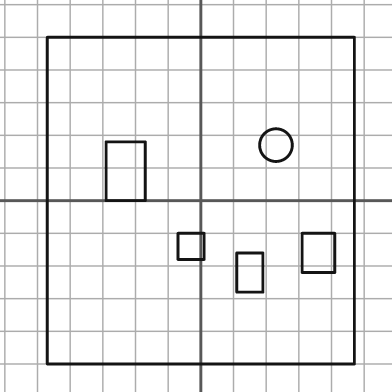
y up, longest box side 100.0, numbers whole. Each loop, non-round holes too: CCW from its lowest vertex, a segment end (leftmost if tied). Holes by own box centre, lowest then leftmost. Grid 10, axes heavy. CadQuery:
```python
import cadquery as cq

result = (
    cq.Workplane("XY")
    .moveTo(-47.0, -50.0)
    .lineTo(47.0, -50.0)
    .lineTo(47.0, 50.0)
    .lineTo(-47.0, 50.0)
    .close()
    .moveTo(11.0, -28.0)
    .lineTo(19.0, -28.0)
    .lineTo(19.0, -16.0)
    .lineTo(11.0, -16.0)
    .close()
    .moveTo(31.0, -22.0)
    .lineTo(41.0, -22.0)
    .lineTo(41.0, -10.0)
    .lineTo(31.0, -10.0)
    .close()
    .moveTo(-7.0, -18.0)
    .lineTo(1.0, -18.0)
    .lineTo(1.0, -10.0)
    .lineTo(-7.0, -10.0)
    .close()
    .moveTo(-29.0, 0.0)
    .lineTo(-17.0, 0.0)
    .lineTo(-17.0, 18.0)
    .lineTo(-29.0, 18.0)
    .close()
    .moveTo(23.0, 17.0)
    .circle(5.0)
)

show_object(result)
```